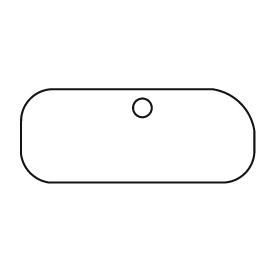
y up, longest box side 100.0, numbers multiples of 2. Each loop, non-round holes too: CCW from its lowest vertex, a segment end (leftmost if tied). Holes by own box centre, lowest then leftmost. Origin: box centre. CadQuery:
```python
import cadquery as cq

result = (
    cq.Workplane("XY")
    .moveTo(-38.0, -20.0)
    .lineTo(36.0, -20.0)
    .threePointArc((46.0, -16.0), (50.0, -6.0))
    .lineTo(50.0, 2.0)
    .threePointArc((44.0, 14.0), (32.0, 20.0))
    .lineTo(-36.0, 20.0)
    .threePointArc((-46.0, 16.0), (-50.0, 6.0))
    .lineTo(-50.0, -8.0)
    .threePointArc((-46.0, -16.0), (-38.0, -20.0))
    .close()
    .moveTo(2.0, 12.0)
    .circle(4.0)
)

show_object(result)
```